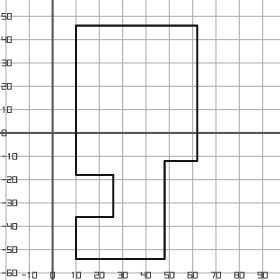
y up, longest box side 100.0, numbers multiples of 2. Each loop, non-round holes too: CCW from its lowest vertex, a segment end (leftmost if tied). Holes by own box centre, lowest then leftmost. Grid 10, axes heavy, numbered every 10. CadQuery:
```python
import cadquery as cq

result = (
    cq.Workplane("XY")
    .moveTo(10.0, -54.0)
    .lineTo(48.0, -54.0)
    .lineTo(48.0, -12.0)
    .lineTo(62.0, -12.0)
    .lineTo(62.0, 46.0)
    .lineTo(10.0, 46.0)
    .lineTo(10.0, -18.0)
    .lineTo(26.0, -18.0)
    .lineTo(26.0, -36.0)
    .lineTo(10.0, -36.0)
    .close()
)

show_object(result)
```